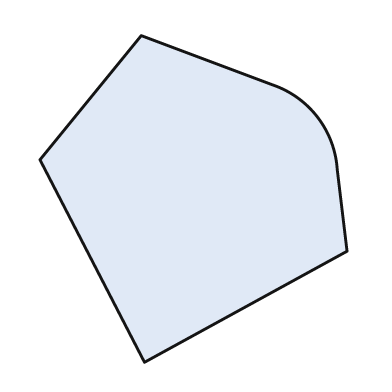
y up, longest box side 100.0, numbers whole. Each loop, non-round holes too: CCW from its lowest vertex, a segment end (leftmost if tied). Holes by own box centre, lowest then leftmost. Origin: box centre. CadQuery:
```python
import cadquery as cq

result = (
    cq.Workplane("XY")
    .moveTo(-15.0, -50.0)
    .lineTo(47.0, -16.0)
    .lineTo(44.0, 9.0)
    .threePointArc((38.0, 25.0), (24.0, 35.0))
    .lineTo(-16.0, 50.0)
    .lineTo(-47.0, 12.0)
    .close()
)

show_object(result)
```